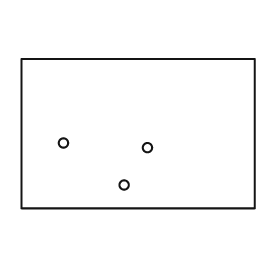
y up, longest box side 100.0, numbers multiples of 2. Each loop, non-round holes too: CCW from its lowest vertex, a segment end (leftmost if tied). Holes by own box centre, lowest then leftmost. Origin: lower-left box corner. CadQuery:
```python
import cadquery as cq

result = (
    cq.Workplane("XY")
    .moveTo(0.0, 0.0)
    .lineTo(100.0, 0.0)
    .lineTo(100.0, 64.0)
    .lineTo(0.0, 64.0)
    .close()
    .moveTo(44.0, 10.0)
    .circle(2.0)
    .moveTo(54.0, 26.0)
    .circle(2.0)
    .moveTo(18.0, 28.0)
    .circle(2.0)
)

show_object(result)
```